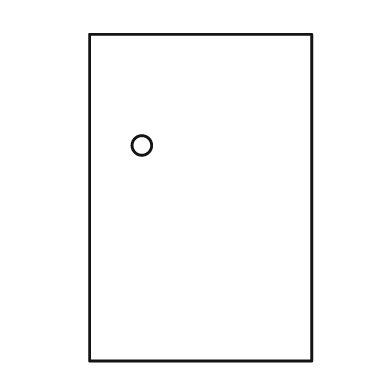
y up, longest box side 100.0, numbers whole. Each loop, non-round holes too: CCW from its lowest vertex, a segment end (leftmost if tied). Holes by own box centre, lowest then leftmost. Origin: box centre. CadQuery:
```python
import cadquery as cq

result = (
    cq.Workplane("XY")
    .moveTo(-34.0, -50.0)
    .lineTo(34.0, -50.0)
    .lineTo(34.0, 50.0)
    .lineTo(-34.0, 50.0)
    .close()
    .moveTo(-18.0, 16.0)
    .circle(3.0)
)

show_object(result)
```